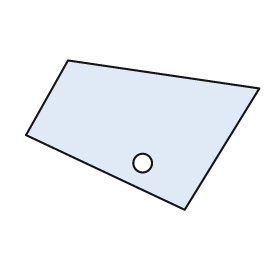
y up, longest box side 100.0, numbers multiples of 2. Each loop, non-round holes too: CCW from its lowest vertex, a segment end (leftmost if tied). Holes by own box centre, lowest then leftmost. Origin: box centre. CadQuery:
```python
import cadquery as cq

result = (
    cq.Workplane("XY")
    .moveTo(18.0, -32.0)
    .lineTo(50.0, 20.0)
    .lineTo(-32.0, 32.0)
    .lineTo(-50.0, 0.0)
    .close()
    .moveTo(0.0, -12.0)
    .circle(4.0)
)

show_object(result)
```